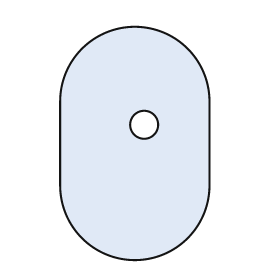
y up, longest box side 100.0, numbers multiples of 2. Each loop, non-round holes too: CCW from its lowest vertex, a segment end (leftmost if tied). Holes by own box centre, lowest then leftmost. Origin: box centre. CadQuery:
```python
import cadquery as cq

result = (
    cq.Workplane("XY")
    .moveTo(-32.0, -18.0)
    .threePointArc((0.0, -50.0), (32.0, -18.0))
    .lineTo(32.0, 18.0)
    .threePointArc((0.0, 50.0), (-32.0, 18.0))
    .close()
    .moveTo(4.0, 8.0)
    .circle(6.0)
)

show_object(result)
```